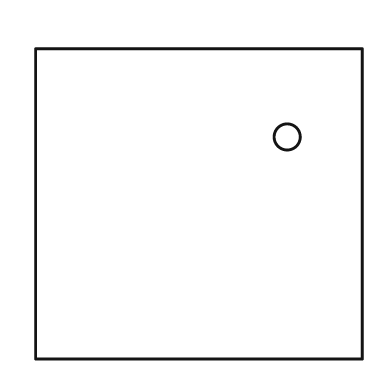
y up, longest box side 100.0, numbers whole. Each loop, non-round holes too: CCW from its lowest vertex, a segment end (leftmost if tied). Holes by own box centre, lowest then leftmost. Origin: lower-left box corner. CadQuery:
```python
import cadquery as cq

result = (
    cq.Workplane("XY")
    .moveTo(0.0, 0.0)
    .lineTo(100.0, 0.0)
    .lineTo(100.0, 95.0)
    .lineTo(0.0, 95.0)
    .close()
    .moveTo(77.0, 68.0)
    .circle(4.0)
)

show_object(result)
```